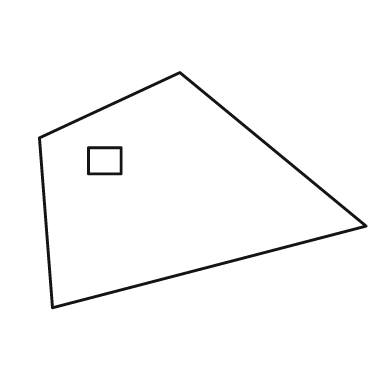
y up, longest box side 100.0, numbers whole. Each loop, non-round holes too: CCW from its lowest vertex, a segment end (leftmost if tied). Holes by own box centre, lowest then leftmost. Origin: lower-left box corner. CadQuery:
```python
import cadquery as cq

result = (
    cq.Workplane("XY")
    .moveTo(4.0, 0.0)
    .lineTo(100.0, 25.0)
    .lineTo(43.0, 72.0)
    .lineTo(0.0, 52.0)
    .close()
    .moveTo(15.0, 41.0)
    .lineTo(25.0, 41.0)
    .lineTo(25.0, 49.0)
    .lineTo(15.0, 49.0)
    .close()
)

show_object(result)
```